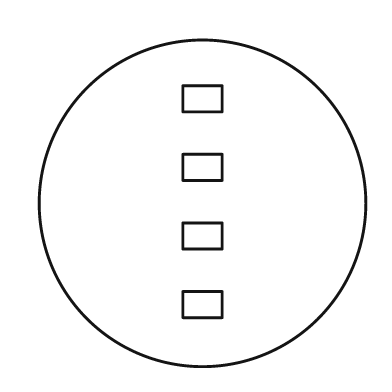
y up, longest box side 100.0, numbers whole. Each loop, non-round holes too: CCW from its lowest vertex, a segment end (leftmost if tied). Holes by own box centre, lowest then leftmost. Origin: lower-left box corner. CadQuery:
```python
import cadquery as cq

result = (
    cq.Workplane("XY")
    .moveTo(50.0, 50.0)
    .circle(50.0)
    .moveTo(44.0, 15.0)
    .lineTo(56.0, 15.0)
    .lineTo(56.0, 23.0)
    .lineTo(44.0, 23.0)
    .close()
    .moveTo(44.0, 36.0)
    .lineTo(56.0, 36.0)
    .lineTo(56.0, 44.0)
    .lineTo(44.0, 44.0)
    .close()
    .moveTo(44.0, 57.0)
    .lineTo(56.0, 57.0)
    .lineTo(56.0, 65.0)
    .lineTo(44.0, 65.0)
    .close()
    .moveTo(44.0, 78.0)
    .lineTo(56.0, 78.0)
    .lineTo(56.0, 86.0)
    .lineTo(44.0, 86.0)
    .close()
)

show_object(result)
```